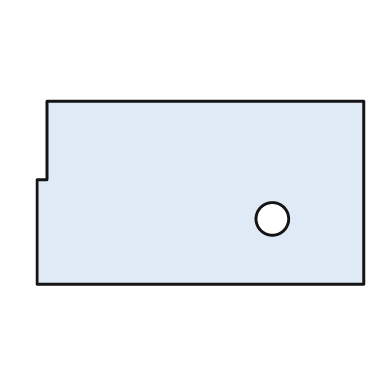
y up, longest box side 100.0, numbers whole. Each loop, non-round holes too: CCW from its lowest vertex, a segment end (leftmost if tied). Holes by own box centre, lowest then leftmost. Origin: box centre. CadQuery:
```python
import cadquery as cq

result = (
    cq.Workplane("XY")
    .moveTo(-50.0, -28.0)
    .lineTo(50.0, -28.0)
    .lineTo(50.0, 28.0)
    .lineTo(-47.0, 28.0)
    .lineTo(-47.0, 4.0)
    .lineTo(-50.0, 4.0)
    .close()
    .moveTo(22.0, -8.0)
    .circle(5.0)
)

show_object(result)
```